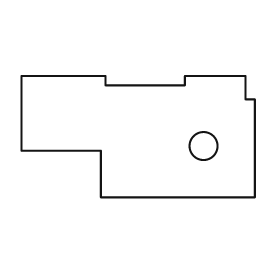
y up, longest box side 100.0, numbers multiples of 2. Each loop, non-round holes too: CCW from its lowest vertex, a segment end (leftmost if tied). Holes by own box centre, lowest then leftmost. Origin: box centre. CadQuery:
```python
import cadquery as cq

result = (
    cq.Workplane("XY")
    .moveTo(-16.0, -26.0)
    .lineTo(50.0, -26.0)
    .lineTo(50.0, 16.0)
    .lineTo(46.0, 16.0)
    .lineTo(46.0, 26.0)
    .lineTo(20.0, 26.0)
    .lineTo(20.0, 22.0)
    .lineTo(-14.0, 22.0)
    .lineTo(-14.0, 26.0)
    .lineTo(-50.0, 26.0)
    .lineTo(-50.0, -6.0)
    .lineTo(-16.0, -6.0)
    .close()
    .moveTo(28.0, -4.0)
    .circle(6.0)
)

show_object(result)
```